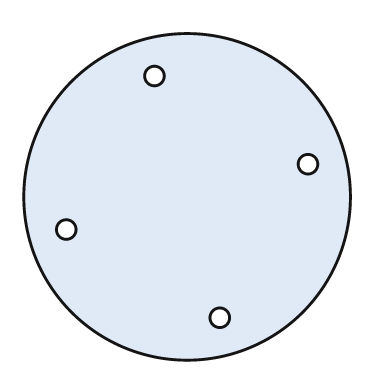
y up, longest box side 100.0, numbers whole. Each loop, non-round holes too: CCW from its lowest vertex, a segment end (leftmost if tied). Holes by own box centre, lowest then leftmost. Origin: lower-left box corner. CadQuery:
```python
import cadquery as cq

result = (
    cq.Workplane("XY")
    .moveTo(50.0, 50.0)
    .circle(50.0)
    .moveTo(60.0, 13.0)
    .circle(3.0)
    .moveTo(13.0, 40.0)
    .circle(3.0)
    .moveTo(87.0, 60.0)
    .circle(3.0)
    .moveTo(40.0, 87.0)
    .circle(3.0)
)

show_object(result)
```